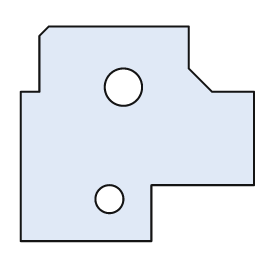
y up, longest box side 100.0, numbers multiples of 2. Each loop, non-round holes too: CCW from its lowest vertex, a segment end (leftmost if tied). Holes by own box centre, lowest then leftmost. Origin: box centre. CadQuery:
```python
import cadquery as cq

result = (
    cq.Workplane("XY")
    .moveTo(-50.0, -46.0)
    .lineTo(6.0, -46.0)
    .lineTo(6.0, -22.0)
    .lineTo(50.0, -22.0)
    .lineTo(50.0, 18.0)
    .lineTo(32.0, 18.0)
    .lineTo(22.0, 28.0)
    .lineTo(22.0, 46.0)
    .lineTo(-38.0, 46.0)
    .lineTo(-42.0, 42.0)
    .lineTo(-42.0, 18.0)
    .lineTo(-50.0, 18.0)
    .close()
    .moveTo(-12.0, -28.0)
    .circle(6.0)
    .moveTo(-6.0, 20.0)
    .circle(8.0)
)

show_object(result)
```